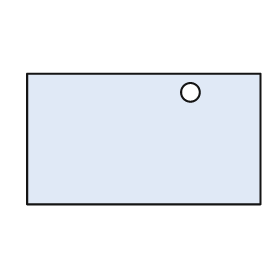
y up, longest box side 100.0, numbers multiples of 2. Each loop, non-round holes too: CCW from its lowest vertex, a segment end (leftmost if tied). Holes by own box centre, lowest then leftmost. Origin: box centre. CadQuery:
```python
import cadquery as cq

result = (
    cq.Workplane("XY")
    .moveTo(-50.0, -28.0)
    .lineTo(50.0, -28.0)
    .lineTo(50.0, 28.0)
    .lineTo(-50.0, 28.0)
    .close()
    .moveTo(20.0, 20.0)
    .circle(4.0)
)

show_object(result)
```